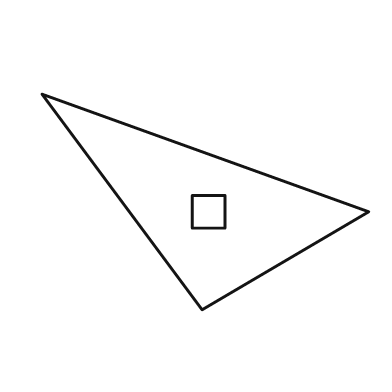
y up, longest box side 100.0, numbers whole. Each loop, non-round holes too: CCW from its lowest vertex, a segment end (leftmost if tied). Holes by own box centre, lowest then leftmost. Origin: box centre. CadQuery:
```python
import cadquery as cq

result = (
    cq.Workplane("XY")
    .moveTo(-1.0, -33.0)
    .lineTo(50.0, -3.0)
    .lineTo(-50.0, 33.0)
    .close()
    .moveTo(-4.0, -8.0)
    .lineTo(6.0, -8.0)
    .lineTo(6.0, 2.0)
    .lineTo(-4.0, 2.0)
    .close()
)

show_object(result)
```